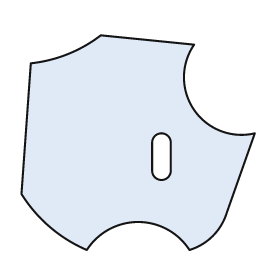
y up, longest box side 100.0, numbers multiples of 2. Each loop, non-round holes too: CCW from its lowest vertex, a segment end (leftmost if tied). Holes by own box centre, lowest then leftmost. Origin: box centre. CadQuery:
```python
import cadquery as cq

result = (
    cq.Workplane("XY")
    .moveTo(-22.0, -46.0)
    .threePointArc((0.0, -34.0), (22.0, -46.0))
    .threePointArc((32.0, -40.0), (38.0, -30.0))
    .lineTo(50.0, 4.0)
    .threePointArc((24.0, 14.0), (24.0, 42.0))
    .lineTo(-16.0, 46.0)
    .threePointArc((-30.0, 38.0), (-46.0, 34.0))
    .lineTo(-50.0, -22.0)
    .threePointArc((-38.0, -36.0), (-22.0, -46.0))
    .close()
    .moveTo(6.0, -12.0)
    .threePointArc((10.0, -16.0), (14.0, -12.0))
    .lineTo(14.0, 0.0)
    .threePointArc((10.0, 4.0), (6.0, 0.0))
    .close()
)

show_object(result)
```